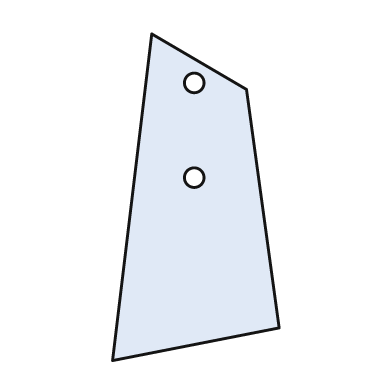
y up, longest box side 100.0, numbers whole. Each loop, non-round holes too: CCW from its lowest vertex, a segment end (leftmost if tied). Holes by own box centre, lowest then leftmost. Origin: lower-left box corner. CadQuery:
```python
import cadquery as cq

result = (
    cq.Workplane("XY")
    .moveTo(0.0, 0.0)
    .lineTo(51.0, 10.0)
    .lineTo(41.0, 83.0)
    .lineTo(12.0, 100.0)
    .close()
    .moveTo(25.0, 56.0)
    .circle(3.0)
    .moveTo(25.0, 85.0)
    .circle(3.0)
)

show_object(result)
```